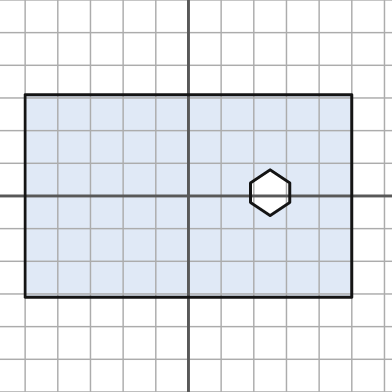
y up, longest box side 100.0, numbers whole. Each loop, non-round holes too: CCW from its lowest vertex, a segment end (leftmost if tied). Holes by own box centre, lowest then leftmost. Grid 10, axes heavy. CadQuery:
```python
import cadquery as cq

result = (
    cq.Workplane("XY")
    .moveTo(-50.0, -31.0)
    .lineTo(50.0, -31.0)
    .lineTo(50.0, 31.0)
    .lineTo(-50.0, 31.0)
    .close()
    .moveTo(25.0, -6.0)
    .lineTo(31.0, -2.0)
    .lineTo(31.0, 4.0)
    .lineTo(25.0, 8.0)
    .lineTo(19.0, 4.0)
    .lineTo(19.0, -2.0)
    .close()
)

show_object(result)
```